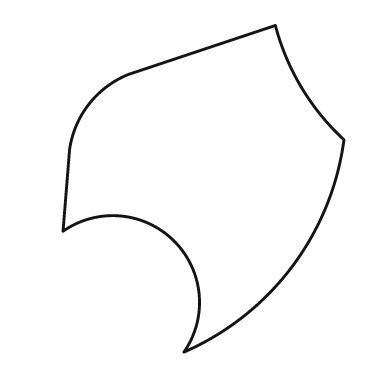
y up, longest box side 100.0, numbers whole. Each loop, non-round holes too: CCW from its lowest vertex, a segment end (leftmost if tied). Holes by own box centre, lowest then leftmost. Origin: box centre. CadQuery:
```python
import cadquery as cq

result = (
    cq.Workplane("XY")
    .moveTo(-6.0, -50.0)
    .threePointArc((27.0, -24.0), (43.0, 15.0))
    .threePointArc((30.0, 31.0), (22.0, 50.0))
    .lineTo(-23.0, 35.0)
    .threePointArc((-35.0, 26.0), (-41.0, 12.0))
    .lineTo(-43.0, -13.0)
    .threePointArc((-9.0, -16.0), (-6.0, -50.0))
    .close()
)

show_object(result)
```